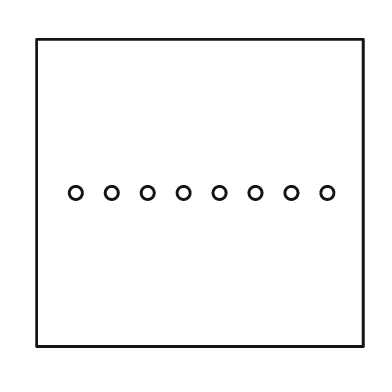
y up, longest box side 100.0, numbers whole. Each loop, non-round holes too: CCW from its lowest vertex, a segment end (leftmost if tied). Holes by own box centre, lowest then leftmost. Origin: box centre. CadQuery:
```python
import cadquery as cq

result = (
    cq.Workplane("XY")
    .moveTo(-50.0, -47.0)
    .lineTo(50.0, -47.0)
    .lineTo(50.0, 47.0)
    .lineTo(-50.0, 47.0)
    .close()
    .moveTo(-38.0, 0.0)
    .circle(2.0)
    .moveTo(-27.0, 0.0)
    .circle(2.0)
    .moveTo(-16.0, 0.0)
    .circle(2.0)
    .moveTo(-5.0, 0.0)
    .circle(2.0)
    .moveTo(6.0, 0.0)
    .circle(2.0)
    .moveTo(17.0, 0.0)
    .circle(2.0)
    .moveTo(28.0, 0.0)
    .circle(2.0)
    .moveTo(39.0, 0.0)
    .circle(2.0)
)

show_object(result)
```